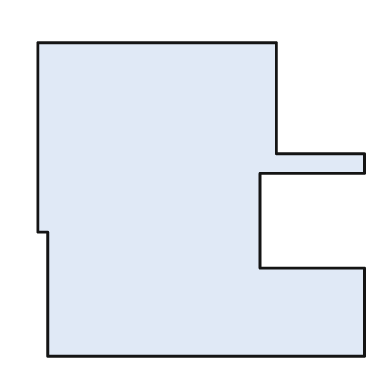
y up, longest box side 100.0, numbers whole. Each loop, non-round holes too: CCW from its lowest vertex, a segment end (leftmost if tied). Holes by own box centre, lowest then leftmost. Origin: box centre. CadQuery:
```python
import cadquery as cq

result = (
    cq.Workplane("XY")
    .moveTo(-47.0, -48.0)
    .lineTo(50.0, -48.0)
    .lineTo(50.0, -21.0)
    .lineTo(18.0, -21.0)
    .lineTo(18.0, 8.0)
    .lineTo(50.0, 8.0)
    .lineTo(50.0, 14.0)
    .lineTo(23.0, 14.0)
    .lineTo(23.0, 48.0)
    .lineTo(-50.0, 48.0)
    .lineTo(-50.0, -10.0)
    .lineTo(-47.0, -10.0)
    .close()
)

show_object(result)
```